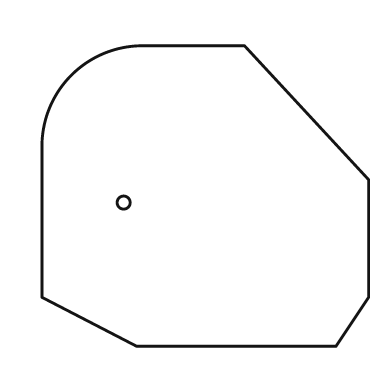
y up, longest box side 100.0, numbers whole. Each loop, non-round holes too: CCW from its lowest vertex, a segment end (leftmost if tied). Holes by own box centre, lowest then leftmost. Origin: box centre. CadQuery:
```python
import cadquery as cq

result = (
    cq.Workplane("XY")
    .moveTo(-21.0, -46.0)
    .lineTo(40.0, -46.0)
    .lineTo(50.0, -31.0)
    .lineTo(50.0, 5.0)
    .lineTo(12.0, 46.0)
    .lineTo(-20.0, 46.0)
    .threePointArc((-41.0, 37.0), (-50.0, 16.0))
    .lineTo(-50.0, -31.0)
    .close()
    .moveTo(-25.0, -2.0)
    .circle(2.0)
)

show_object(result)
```